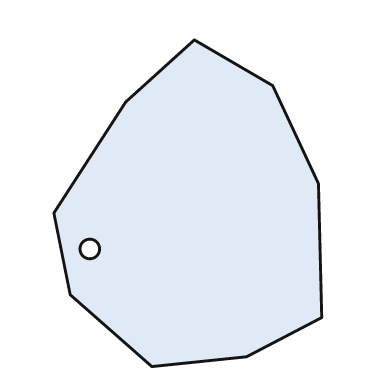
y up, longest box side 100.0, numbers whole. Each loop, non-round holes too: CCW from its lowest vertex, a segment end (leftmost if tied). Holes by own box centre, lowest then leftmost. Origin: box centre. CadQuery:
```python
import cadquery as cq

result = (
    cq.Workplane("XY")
    .moveTo(-11.0, -50.0)
    .lineTo(18.0, -47.0)
    .lineTo(41.0, -35.0)
    .lineTo(40.0, 6.0)
    .lineTo(26.0, 36.0)
    .lineTo(2.0, 50.0)
    .lineTo(-19.0, 31.0)
    .lineTo(-41.0, -3.0)
    .lineTo(-36.0, -28.0)
    .close()
    .moveTo(-30.0, -14.0)
    .circle(3.0)
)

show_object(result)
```